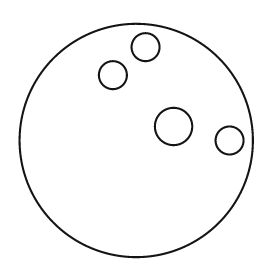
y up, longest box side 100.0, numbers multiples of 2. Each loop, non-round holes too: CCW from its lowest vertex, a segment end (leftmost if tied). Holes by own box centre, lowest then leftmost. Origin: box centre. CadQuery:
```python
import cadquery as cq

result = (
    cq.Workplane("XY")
    .moveTo(0.0, 0.0)
    .circle(50.0)
    .moveTo(40.0, 0.0)
    .circle(6.0)
    .moveTo(16.0, 6.0)
    .circle(8.0)
    .moveTo(-10.0, 28.0)
    .circle(6.0)
    .moveTo(4.0, 40.0)
    .circle(6.0)
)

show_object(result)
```